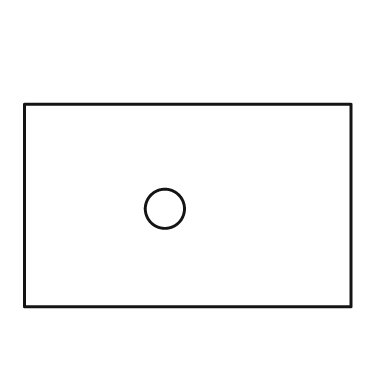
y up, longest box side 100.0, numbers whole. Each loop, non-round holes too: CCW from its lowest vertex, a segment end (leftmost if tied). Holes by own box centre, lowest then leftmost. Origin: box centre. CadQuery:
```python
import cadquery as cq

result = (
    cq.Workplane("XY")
    .moveTo(-50.0, -31.0)
    .lineTo(50.0, -31.0)
    .lineTo(50.0, 31.0)
    .lineTo(-50.0, 31.0)
    .close()
    .moveTo(-7.0, -1.0)
    .circle(6.0)
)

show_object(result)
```